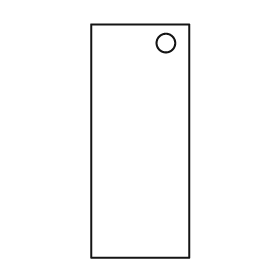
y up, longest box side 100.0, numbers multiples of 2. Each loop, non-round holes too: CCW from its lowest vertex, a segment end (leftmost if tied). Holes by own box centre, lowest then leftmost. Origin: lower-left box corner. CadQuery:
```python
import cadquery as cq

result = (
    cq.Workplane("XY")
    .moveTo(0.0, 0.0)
    .lineTo(42.0, 0.0)
    .lineTo(42.0, 100.0)
    .lineTo(0.0, 100.0)
    .close()
    .moveTo(32.0, 92.0)
    .circle(4.0)
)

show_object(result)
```